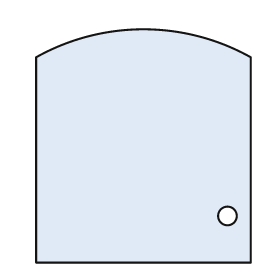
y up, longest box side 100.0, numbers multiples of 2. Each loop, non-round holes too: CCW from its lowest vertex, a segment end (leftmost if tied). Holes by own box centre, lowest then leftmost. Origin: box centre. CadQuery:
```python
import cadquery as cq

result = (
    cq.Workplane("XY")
    .moveTo(-46.0, -50.0)
    .lineTo(46.0, -50.0)
    .lineTo(46.0, 38.0)
    .threePointArc((0.0, 50.0), (-46.0, 38.0))
    .close()
    .moveTo(36.0, -30.0)
    .circle(4.0)
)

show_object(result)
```